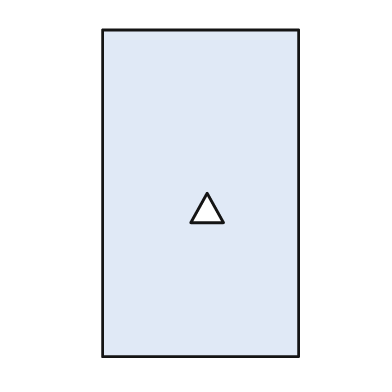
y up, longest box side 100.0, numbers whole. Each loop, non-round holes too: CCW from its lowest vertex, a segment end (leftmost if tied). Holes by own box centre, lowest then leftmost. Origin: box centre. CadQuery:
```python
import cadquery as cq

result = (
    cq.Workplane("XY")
    .moveTo(-30.0, -50.0)
    .lineTo(30.0, -50.0)
    .lineTo(30.0, 50.0)
    .lineTo(-30.0, 50.0)
    .close()
    .moveTo(-3.0, -9.0)
    .lineTo(7.0, -9.0)
    .lineTo(2.0, 0.0)
    .close()
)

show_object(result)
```